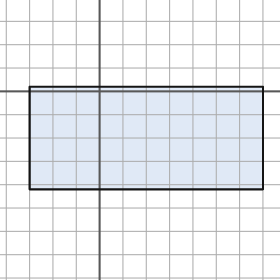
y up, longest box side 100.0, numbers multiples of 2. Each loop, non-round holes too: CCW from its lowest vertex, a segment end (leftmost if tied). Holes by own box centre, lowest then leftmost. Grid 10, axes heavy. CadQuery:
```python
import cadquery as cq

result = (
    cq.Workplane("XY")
    .moveTo(-30.0, -42.0)
    .lineTo(70.0, -42.0)
    .lineTo(70.0, 2.0)
    .lineTo(-30.0, 2.0)
    .close()
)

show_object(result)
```